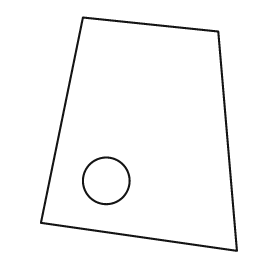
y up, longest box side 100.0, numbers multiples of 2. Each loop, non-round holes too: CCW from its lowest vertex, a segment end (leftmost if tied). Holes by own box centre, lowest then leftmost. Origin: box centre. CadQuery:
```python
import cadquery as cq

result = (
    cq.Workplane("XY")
    .moveTo(42.0, -50.0)
    .lineTo(34.0, 44.0)
    .lineTo(-24.0, 50.0)
    .lineTo(-42.0, -38.0)
    .close()
    .moveTo(-14.0, -20.0)
    .circle(10.0)
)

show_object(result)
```